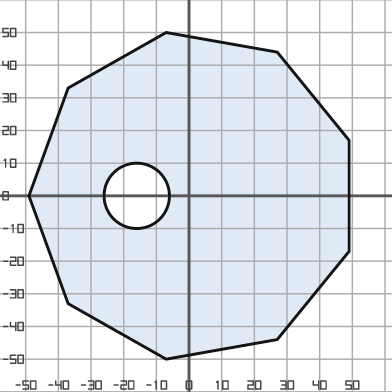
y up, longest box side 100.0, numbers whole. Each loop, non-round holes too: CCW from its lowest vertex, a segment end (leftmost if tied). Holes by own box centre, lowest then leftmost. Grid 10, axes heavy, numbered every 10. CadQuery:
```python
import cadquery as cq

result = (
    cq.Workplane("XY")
    .moveTo(-7.0, -50.0)
    .lineTo(27.0, -44.0)
    .lineTo(49.0, -17.0)
    .lineTo(49.0, 17.0)
    .lineTo(27.0, 44.0)
    .lineTo(-7.0, 50.0)
    .lineTo(-37.0, 33.0)
    .lineTo(-49.0, 0.0)
    .lineTo(-37.0, -33.0)
    .close()
    .moveTo(-16.0, 0.0)
    .circle(10.0)
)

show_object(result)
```